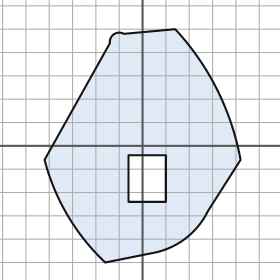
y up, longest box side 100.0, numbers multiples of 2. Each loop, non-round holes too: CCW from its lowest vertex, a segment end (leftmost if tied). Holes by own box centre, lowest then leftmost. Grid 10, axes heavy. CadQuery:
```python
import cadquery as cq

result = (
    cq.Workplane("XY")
    .moveTo(-16.0, -50.0)
    .lineTo(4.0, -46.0)
    .threePointArc((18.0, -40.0), (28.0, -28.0))
    .lineTo(42.0, -6.0)
    .threePointArc((32.0, 24.0), (14.0, 50.0))
    .lineTo(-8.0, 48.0)
    .threePointArc((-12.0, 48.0), (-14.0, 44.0))
    .lineTo(-42.0, -6.0)
    .threePointArc((-32.0, -30.0), (-16.0, -50.0))
    .close()
    .moveTo(-6.0, -24.0)
    .lineTo(10.0, -24.0)
    .lineTo(10.0, -4.0)
    .lineTo(-6.0, -4.0)
    .close()
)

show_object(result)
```